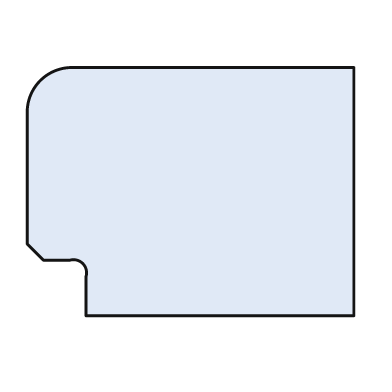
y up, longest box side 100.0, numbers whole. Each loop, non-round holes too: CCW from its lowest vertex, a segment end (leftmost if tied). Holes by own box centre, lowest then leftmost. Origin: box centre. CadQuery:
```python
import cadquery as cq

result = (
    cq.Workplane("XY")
    .moveTo(-32.0, -38.0)
    .lineTo(50.0, -38.0)
    .lineTo(50.0, 38.0)
    .lineTo(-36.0, 38.0)
    .threePointArc((-46.0, 34.0), (-50.0, 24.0))
    .lineTo(-50.0, -16.0)
    .lineTo(-45.0, -21.0)
    .lineTo(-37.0, -21.0)
    .threePointArc((-33.0, -22.0), (-32.0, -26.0))
    .close()
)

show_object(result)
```